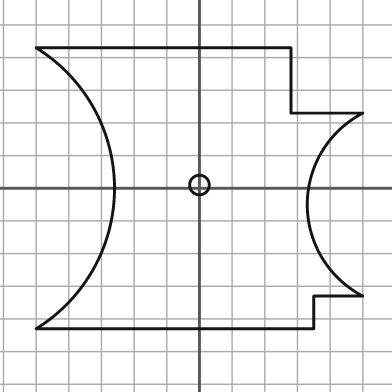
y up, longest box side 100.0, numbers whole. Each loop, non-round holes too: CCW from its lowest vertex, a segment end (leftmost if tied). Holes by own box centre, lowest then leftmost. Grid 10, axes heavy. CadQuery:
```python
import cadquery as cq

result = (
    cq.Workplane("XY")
    .moveTo(-50.0, -43.0)
    .lineTo(35.0, -43.0)
    .lineTo(35.0, -33.0)
    .lineTo(50.0, -33.0)
    .threePointArc((33.0, -5.0), (50.0, 23.0))
    .lineTo(28.0, 23.0)
    .lineTo(28.0, 43.0)
    .lineTo(-50.0, 43.0)
    .threePointArc((-26.0, 0.0), (-50.0, -43.0))
    .close()
    .moveTo(0.0, 1.0)
    .circle(3.0)
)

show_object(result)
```